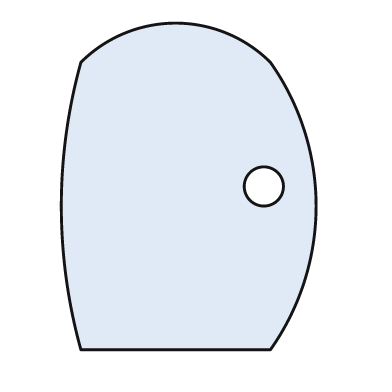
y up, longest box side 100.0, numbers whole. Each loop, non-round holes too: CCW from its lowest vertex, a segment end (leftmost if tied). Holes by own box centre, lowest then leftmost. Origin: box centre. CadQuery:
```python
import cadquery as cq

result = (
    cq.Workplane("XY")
    .moveTo(-33.0, -50.0)
    .lineTo(25.0, -50.0)
    .threePointArc((39.0, -6.0), (25.0, 38.0))
    .threePointArc((-4.0, 50.0), (-33.0, 38.0))
    .threePointArc((-39.0, -6.0), (-33.0, -50.0))
    .close()
    .moveTo(23.0, 0.0)
    .circle(6.0)
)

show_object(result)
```